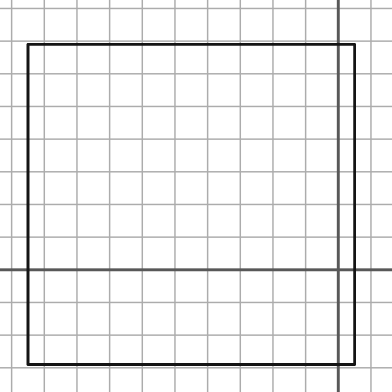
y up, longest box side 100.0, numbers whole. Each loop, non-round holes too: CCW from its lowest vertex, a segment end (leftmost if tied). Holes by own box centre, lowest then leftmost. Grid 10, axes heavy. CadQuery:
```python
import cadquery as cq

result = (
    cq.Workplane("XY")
    .moveTo(-95.0, -29.0)
    .lineTo(5.0, -29.0)
    .lineTo(5.0, 69.0)
    .lineTo(-95.0, 69.0)
    .close()
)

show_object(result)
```